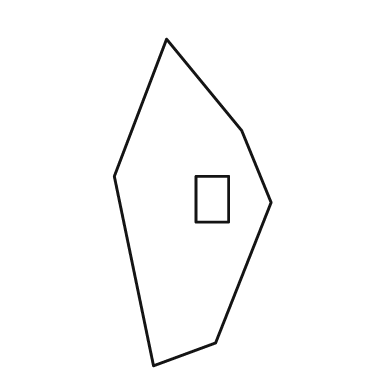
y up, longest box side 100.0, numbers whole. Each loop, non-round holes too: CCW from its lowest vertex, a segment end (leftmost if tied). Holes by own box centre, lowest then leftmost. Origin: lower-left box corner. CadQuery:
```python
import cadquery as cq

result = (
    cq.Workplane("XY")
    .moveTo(12.0, 0.0)
    .lineTo(31.0, 7.0)
    .lineTo(48.0, 50.0)
    .lineTo(39.0, 72.0)
    .lineTo(16.0, 100.0)
    .lineTo(0.0, 58.0)
    .close()
    .moveTo(25.0, 44.0)
    .lineTo(35.0, 44.0)
    .lineTo(35.0, 58.0)
    .lineTo(25.0, 58.0)
    .close()
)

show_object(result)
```